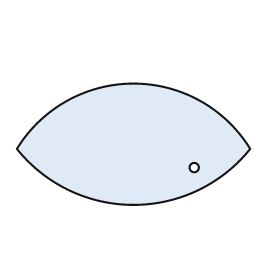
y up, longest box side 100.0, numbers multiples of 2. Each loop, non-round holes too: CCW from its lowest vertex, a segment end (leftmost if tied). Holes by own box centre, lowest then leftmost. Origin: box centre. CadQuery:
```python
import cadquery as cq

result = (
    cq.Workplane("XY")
    .moveTo(-50.0, -2.0)
    .threePointArc((0.0, -26.0), (50.0, -2.0))
    .threePointArc((0.0, 26.0), (-50.0, -2.0))
    .close()
    .moveTo(26.0, -10.0)
    .circle(2.0)
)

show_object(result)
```